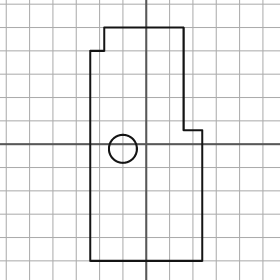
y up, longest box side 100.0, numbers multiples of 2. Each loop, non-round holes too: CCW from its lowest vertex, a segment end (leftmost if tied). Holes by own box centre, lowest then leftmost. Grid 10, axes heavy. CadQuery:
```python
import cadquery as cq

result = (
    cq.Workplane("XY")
    .moveTo(-24.0, -50.0)
    .lineTo(24.0, -50.0)
    .lineTo(24.0, 6.0)
    .lineTo(16.0, 6.0)
    .lineTo(16.0, 50.0)
    .lineTo(-18.0, 50.0)
    .lineTo(-18.0, 40.0)
    .lineTo(-24.0, 40.0)
    .close()
    .moveTo(-10.0, -2.0)
    .circle(6.0)
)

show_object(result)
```